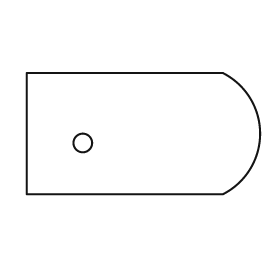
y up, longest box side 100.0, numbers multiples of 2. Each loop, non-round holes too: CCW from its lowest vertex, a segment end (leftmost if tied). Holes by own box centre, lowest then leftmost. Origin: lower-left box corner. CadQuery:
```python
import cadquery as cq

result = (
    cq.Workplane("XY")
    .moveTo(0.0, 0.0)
    .lineTo(84.0, 0.0)
    .threePointArc((100.0, 26.0), (84.0, 52.0))
    .lineTo(0.0, 52.0)
    .close()
    .moveTo(24.0, 22.0)
    .circle(4.0)
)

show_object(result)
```